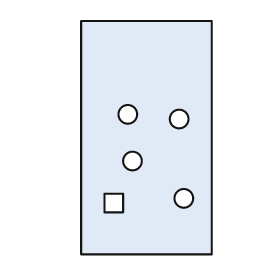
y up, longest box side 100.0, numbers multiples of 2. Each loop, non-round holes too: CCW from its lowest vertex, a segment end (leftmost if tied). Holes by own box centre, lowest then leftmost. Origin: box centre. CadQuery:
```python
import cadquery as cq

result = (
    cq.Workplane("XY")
    .moveTo(-28.0, -50.0)
    .lineTo(28.0, -50.0)
    .lineTo(28.0, 50.0)
    .lineTo(-28.0, 50.0)
    .close()
    .moveTo(-18.0, -32.0)
    .lineTo(-10.0, -32.0)
    .lineTo(-10.0, -24.0)
    .lineTo(-18.0, -24.0)
    .close()
    .moveTo(16.0, -26.0)
    .circle(4.0)
    .moveTo(-6.0, -10.0)
    .circle(4.0)
    .moveTo(14.0, 8.0)
    .circle(4.0)
    .moveTo(-8.0, 10.0)
    .circle(4.0)
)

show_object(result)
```